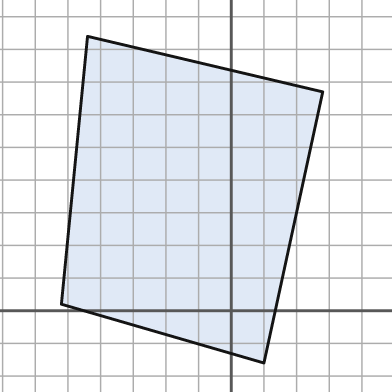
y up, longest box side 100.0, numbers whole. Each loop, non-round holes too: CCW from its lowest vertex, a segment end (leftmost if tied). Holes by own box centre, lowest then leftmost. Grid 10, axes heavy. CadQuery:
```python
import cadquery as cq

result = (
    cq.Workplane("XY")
    .moveTo(10.0, -16.0)
    .lineTo(28.0, 67.0)
    .lineTo(-44.0, 84.0)
    .lineTo(-52.0, 2.0)
    .close()
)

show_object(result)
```